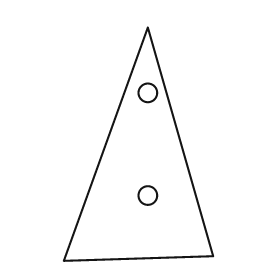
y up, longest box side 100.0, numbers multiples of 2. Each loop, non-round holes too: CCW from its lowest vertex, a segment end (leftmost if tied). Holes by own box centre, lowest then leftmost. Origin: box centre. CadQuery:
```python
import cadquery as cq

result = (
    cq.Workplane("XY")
    .moveTo(-32.0, -50.0)
    .lineTo(32.0, -48.0)
    .lineTo(4.0, 50.0)
    .close()
    .moveTo(4.0, -22.0)
    .circle(4.0)
    .moveTo(4.0, 22.0)
    .circle(4.0)
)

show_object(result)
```